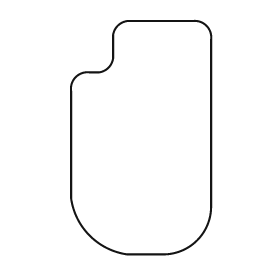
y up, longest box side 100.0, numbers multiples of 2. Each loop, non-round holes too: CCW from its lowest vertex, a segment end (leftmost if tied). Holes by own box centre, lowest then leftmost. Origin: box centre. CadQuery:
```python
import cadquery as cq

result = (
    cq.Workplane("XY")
    .moveTo(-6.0, -50.0)
    .lineTo(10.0, -50.0)
    .threePointArc((24.0, -44.0), (30.0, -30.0))
    .lineTo(30.0, 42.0)
    .threePointArc((28.0, 48.0), (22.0, 50.0))
    .lineTo(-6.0, 50.0)
    .threePointArc((-10.0, 48.0), (-12.0, 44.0))
    .lineTo(-12.0, 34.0)
    .threePointArc((-14.0, 30.0), (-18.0, 28.0))
    .lineTo(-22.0, 28.0)
    .threePointArc((-28.0, 26.0), (-30.0, 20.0))
    .lineTo(-30.0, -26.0)
    .threePointArc((-22.0, -42.0), (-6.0, -50.0))
    .close()
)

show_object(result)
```